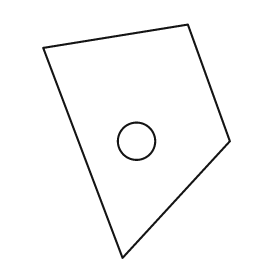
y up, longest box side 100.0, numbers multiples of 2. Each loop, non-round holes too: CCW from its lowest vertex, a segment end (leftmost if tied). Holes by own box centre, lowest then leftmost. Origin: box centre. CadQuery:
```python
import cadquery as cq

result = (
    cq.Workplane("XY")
    .moveTo(-6.0, -50.0)
    .lineTo(40.0, 0.0)
    .lineTo(22.0, 50.0)
    .lineTo(-40.0, 40.0)
    .close()
    .moveTo(0.0, 0.0)
    .circle(8.0)
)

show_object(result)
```